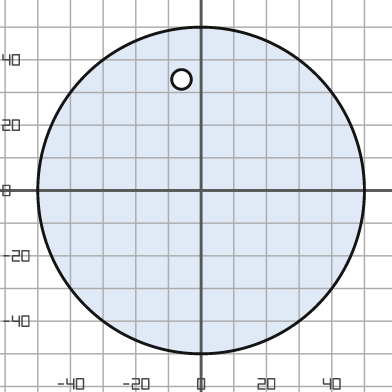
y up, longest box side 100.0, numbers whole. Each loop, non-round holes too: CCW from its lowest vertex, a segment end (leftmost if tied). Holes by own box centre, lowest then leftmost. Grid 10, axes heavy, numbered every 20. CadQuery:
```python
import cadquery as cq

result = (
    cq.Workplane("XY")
    .moveTo(0.0, 0.0)
    .circle(50.0)
    .moveTo(-6.0, 34.0)
    .circle(3.0)
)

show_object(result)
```